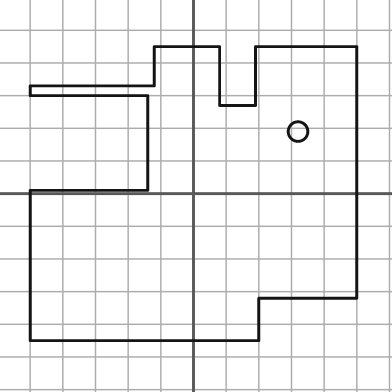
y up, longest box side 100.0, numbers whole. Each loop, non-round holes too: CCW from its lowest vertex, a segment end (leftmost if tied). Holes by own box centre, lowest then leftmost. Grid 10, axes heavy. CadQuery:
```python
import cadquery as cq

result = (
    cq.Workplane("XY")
    .moveTo(-50.0, -45.0)
    .lineTo(20.0, -45.0)
    .lineTo(20.0, -32.0)
    .lineTo(50.0, -32.0)
    .lineTo(50.0, 45.0)
    .lineTo(19.0, 45.0)
    .lineTo(19.0, 27.0)
    .lineTo(8.0, 27.0)
    .lineTo(8.0, 45.0)
    .lineTo(-12.0, 45.0)
    .lineTo(-12.0, 33.0)
    .lineTo(-50.0, 33.0)
    .lineTo(-50.0, 30.0)
    .lineTo(-14.0, 30.0)
    .lineTo(-14.0, 1.0)
    .lineTo(-50.0, 1.0)
    .close()
    .moveTo(32.0, 19.0)
    .circle(3.0)
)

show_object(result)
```